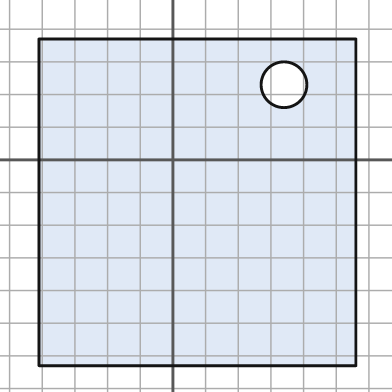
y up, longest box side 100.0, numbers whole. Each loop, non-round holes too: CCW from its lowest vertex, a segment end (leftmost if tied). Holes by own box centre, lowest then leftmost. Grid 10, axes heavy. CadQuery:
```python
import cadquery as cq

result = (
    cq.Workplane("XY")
    .moveTo(-41.0, -63.0)
    .lineTo(56.0, -63.0)
    .lineTo(56.0, 37.0)
    .lineTo(-41.0, 37.0)
    .close()
    .moveTo(34.0, 23.0)
    .circle(7.0)
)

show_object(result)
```